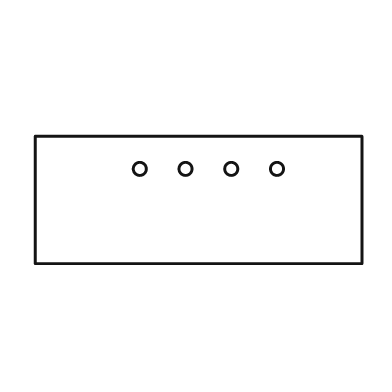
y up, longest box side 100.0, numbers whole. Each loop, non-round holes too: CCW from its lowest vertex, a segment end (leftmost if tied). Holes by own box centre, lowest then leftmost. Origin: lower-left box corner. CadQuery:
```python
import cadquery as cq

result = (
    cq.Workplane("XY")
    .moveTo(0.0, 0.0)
    .lineTo(100.0, 0.0)
    .lineTo(100.0, 39.0)
    .lineTo(0.0, 39.0)
    .close()
    .moveTo(32.0, 29.0)
    .circle(2.0)
    .moveTo(46.0, 29.0)
    .circle(2.0)
    .moveTo(60.0, 29.0)
    .circle(2.0)
    .moveTo(74.0, 29.0)
    .circle(2.0)
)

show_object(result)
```